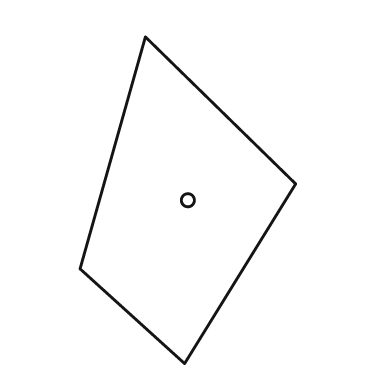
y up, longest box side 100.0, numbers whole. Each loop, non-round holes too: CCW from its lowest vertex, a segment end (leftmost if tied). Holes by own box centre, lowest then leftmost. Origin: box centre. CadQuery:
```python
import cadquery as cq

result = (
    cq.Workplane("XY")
    .moveTo(-1.0, -50.0)
    .lineTo(33.0, 5.0)
    .lineTo(-13.0, 50.0)
    .lineTo(-33.0, -21.0)
    .close()
    .moveTo(0.0, 0.0)
    .circle(2.0)
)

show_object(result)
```